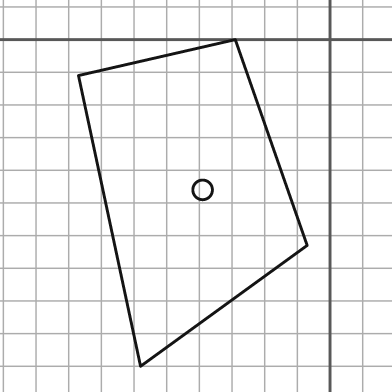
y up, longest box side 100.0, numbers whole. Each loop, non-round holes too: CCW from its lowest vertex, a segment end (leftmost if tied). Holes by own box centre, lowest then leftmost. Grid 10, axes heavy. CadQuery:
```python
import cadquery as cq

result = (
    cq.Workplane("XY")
    .moveTo(-58.0, -100.0)
    .lineTo(-7.0, -63.0)
    .lineTo(-29.0, 0.0)
    .lineTo(-77.0, -11.0)
    .close()
    .moveTo(-39.0, -46.0)
    .circle(3.0)
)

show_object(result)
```